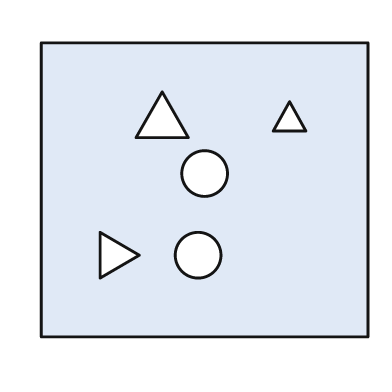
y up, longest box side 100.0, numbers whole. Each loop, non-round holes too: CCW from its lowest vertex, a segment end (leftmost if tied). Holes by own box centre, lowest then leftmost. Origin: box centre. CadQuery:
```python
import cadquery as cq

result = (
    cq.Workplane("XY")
    .moveTo(-50.0, -45.0)
    .lineTo(50.0, -45.0)
    .lineTo(50.0, 45.0)
    .lineTo(-50.0, 45.0)
    .close()
    .moveTo(-32.0, -27.0)
    .lineTo(-20.0, -20.0)
    .lineTo(-32.0, -13.0)
    .close()
    .moveTo(-2.0, -20.0)
    .circle(7.0)
    .moveTo(0.0, 5.0)
    .circle(7.0)
    .moveTo(21.0, 18.0)
    .lineTo(31.0, 18.0)
    .lineTo(26.0, 27.0)
    .close()
    .moveTo(-21.0, 16.0)
    .lineTo(-5.0, 16.0)
    .lineTo(-13.0, 30.0)
    .close()
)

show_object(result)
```